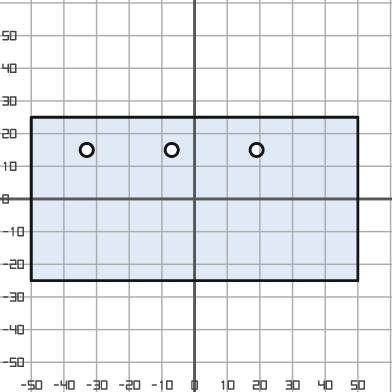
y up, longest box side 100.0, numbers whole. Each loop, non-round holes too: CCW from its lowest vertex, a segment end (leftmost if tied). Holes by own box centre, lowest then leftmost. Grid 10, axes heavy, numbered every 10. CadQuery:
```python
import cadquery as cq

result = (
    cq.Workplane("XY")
    .moveTo(-50.0, -25.0)
    .lineTo(50.0, -25.0)
    .lineTo(50.0, 25.0)
    .lineTo(-50.0, 25.0)
    .close()
    .moveTo(-33.0, 15.0)
    .circle(2.0)
    .moveTo(-7.0, 15.0)
    .circle(2.0)
    .moveTo(19.0, 15.0)
    .circle(2.0)
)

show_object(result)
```